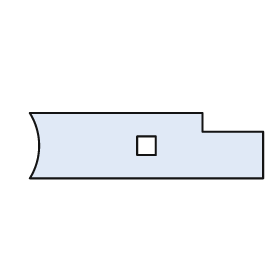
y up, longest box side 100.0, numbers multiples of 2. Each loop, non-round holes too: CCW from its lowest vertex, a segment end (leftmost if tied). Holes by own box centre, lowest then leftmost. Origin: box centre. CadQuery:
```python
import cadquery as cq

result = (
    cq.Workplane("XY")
    .moveTo(-50.0, -14.0)
    .lineTo(50.0, -14.0)
    .lineTo(50.0, 6.0)
    .lineTo(24.0, 6.0)
    .lineTo(24.0, 14.0)
    .lineTo(-50.0, 14.0)
    .threePointArc((-46.0, 0.0), (-50.0, -14.0))
    .close()
    .moveTo(-4.0, -4.0)
    .lineTo(4.0, -4.0)
    .lineTo(4.0, 4.0)
    .lineTo(-4.0, 4.0)
    .close()
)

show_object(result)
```